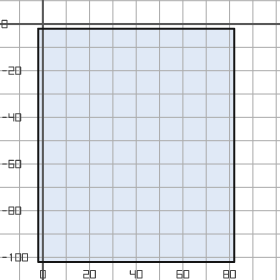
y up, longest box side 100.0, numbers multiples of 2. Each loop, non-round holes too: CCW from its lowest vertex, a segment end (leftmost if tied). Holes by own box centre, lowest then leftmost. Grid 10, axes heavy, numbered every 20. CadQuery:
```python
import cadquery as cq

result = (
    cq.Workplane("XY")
    .moveTo(-2.0, -102.0)
    .lineTo(82.0, -102.0)
    .lineTo(82.0, -2.0)
    .lineTo(-2.0, -2.0)
    .close()
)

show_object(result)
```